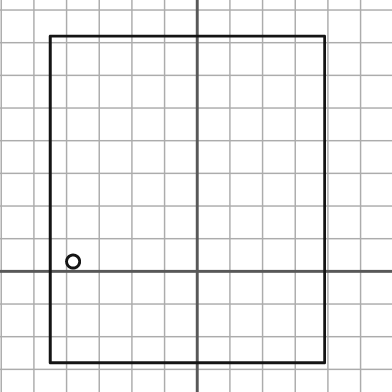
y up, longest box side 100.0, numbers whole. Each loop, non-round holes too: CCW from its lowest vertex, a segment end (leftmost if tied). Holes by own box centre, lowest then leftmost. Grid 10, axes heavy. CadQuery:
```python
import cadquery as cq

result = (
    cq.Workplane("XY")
    .moveTo(-45.0, -28.0)
    .lineTo(39.0, -28.0)
    .lineTo(39.0, 72.0)
    .lineTo(-45.0, 72.0)
    .close()
    .moveTo(-38.0, 3.0)
    .circle(2.0)
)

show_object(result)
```